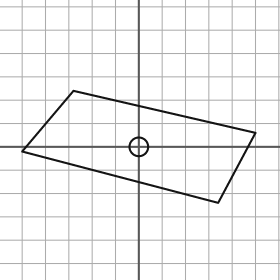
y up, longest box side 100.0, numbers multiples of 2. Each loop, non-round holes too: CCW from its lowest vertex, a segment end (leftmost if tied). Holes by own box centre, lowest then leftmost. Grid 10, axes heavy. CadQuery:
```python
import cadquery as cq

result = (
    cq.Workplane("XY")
    .moveTo(34.0, -24.0)
    .lineTo(50.0, 6.0)
    .lineTo(-28.0, 24.0)
    .lineTo(-50.0, -2.0)
    .close()
    .moveTo(0.0, 0.0)
    .circle(4.0)
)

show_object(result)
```